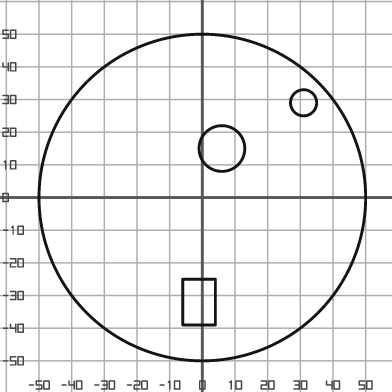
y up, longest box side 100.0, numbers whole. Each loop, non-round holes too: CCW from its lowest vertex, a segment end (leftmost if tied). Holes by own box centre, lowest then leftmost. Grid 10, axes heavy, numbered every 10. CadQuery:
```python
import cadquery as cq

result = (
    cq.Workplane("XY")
    .moveTo(0.0, 0.0)
    .circle(50.0)
    .moveTo(-6.0, -39.0)
    .lineTo(4.0, -39.0)
    .lineTo(4.0, -25.0)
    .lineTo(-6.0, -25.0)
    .close()
    .moveTo(6.0, 15.0)
    .circle(7.0)
    .moveTo(31.0, 29.0)
    .circle(4.0)
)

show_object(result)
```